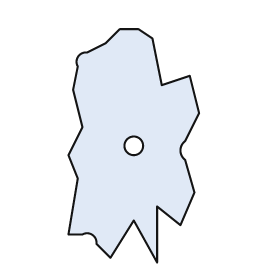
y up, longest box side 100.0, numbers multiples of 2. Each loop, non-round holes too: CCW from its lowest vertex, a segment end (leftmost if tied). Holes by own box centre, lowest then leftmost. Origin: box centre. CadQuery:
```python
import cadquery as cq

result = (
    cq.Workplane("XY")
    .moveTo(10.0, -50.0)
    .lineTo(10.0, -26.0)
    .lineTo(20.0, -34.0)
    .lineTo(26.0, -20.0)
    .lineTo(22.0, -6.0)
    .threePointArc((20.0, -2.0), (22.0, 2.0))
    .lineTo(28.0, 14.0)
    .lineTo(24.0, 30.0)
    .lineTo(12.0, 26.0)
    .lineTo(8.0, 46.0)
    .lineTo(2.0, 50.0)
    .lineTo(-6.0, 50.0)
    .lineTo(-12.0, 44.0)
    .lineTo(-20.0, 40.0)
    .threePointArc((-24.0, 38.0), (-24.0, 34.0))
    .lineTo(-26.0, 24.0)
    .lineTo(-22.0, 8.0)
    .lineTo(-28.0, -4.0)
    .lineTo(-24.0, -14.0)
    .lineTo(-28.0, -38.0)
    .lineTo(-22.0, -38.0)
    .threePointArc((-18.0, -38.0), (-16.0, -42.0))
    .lineTo(-10.0, -48.0)
    .lineTo(0.0, -32.0)
    .close()
    .moveTo(0.0, 0.0)
    .circle(4.0)
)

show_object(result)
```